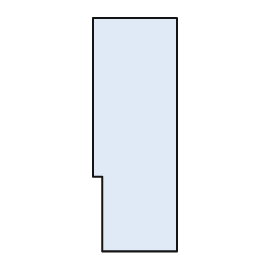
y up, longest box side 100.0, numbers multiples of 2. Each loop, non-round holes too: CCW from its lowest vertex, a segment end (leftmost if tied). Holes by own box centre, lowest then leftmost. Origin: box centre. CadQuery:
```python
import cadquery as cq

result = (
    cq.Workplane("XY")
    .moveTo(-14.0, -50.0)
    .lineTo(18.0, -50.0)
    .lineTo(18.0, 50.0)
    .lineTo(-18.0, 50.0)
    .lineTo(-18.0, -18.0)
    .lineTo(-14.0, -18.0)
    .close()
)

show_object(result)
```